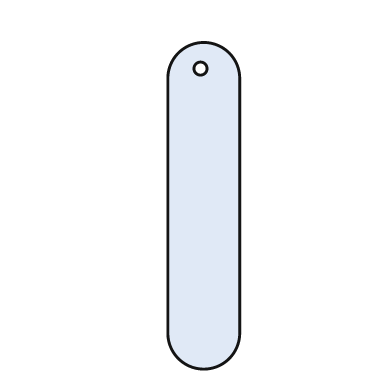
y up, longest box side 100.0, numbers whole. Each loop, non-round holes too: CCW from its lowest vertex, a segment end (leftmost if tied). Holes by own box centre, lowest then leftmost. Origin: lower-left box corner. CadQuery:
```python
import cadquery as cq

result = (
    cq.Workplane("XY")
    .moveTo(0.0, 11.0)
    .threePointArc((11.0, 0.0), (22.0, 11.0))
    .lineTo(22.0, 89.0)
    .threePointArc((11.0, 100.0), (0.0, 89.0))
    .close()
    .moveTo(10.0, 92.0)
    .circle(2.0)
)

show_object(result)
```